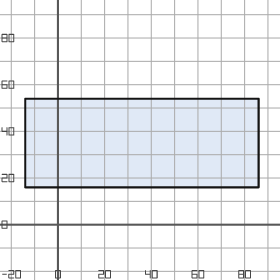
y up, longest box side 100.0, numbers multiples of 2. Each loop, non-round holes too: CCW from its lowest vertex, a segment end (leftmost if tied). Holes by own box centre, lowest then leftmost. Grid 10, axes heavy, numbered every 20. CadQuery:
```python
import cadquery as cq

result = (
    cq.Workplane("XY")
    .moveTo(-14.0, 16.0)
    .lineTo(86.0, 16.0)
    .lineTo(86.0, 54.0)
    .lineTo(-14.0, 54.0)
    .close()
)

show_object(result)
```